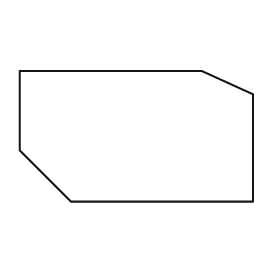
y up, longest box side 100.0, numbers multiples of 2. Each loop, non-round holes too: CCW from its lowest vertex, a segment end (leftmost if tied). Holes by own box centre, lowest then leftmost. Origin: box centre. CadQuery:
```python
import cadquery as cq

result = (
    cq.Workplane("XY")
    .moveTo(-28.0, -28.0)
    .lineTo(50.0, -28.0)
    .lineTo(50.0, 18.0)
    .lineTo(28.0, 28.0)
    .lineTo(-50.0, 28.0)
    .lineTo(-50.0, -6.0)
    .close()
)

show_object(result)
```